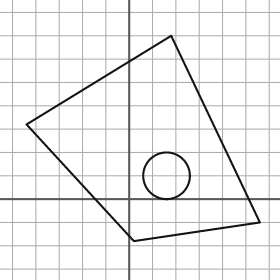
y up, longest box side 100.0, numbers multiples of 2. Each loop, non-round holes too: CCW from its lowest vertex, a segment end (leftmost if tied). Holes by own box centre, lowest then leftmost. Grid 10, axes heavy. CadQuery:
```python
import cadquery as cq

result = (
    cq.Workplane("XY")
    .moveTo(2.0, -18.0)
    .lineTo(56.0, -10.0)
    .lineTo(18.0, 70.0)
    .lineTo(-44.0, 32.0)
    .close()
    .moveTo(16.0, 10.0)
    .circle(10.0)
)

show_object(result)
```